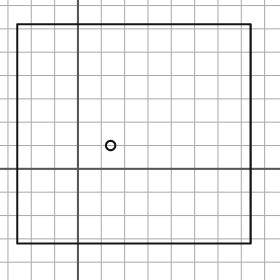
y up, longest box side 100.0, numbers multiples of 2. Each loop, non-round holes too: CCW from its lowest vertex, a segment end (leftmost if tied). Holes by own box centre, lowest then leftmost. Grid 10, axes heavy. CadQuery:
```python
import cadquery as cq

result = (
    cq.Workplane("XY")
    .moveTo(-26.0, -32.0)
    .lineTo(74.0, -32.0)
    .lineTo(74.0, 62.0)
    .lineTo(-26.0, 62.0)
    .close()
    .moveTo(14.0, 10.0)
    .circle(2.0)
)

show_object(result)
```